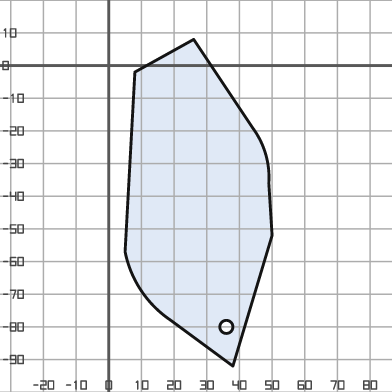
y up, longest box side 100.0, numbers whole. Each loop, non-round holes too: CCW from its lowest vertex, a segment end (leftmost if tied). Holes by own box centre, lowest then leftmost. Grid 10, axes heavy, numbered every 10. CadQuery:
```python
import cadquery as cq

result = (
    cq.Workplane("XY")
    .moveTo(38.0, -92.0)
    .lineTo(50.0, -52.0)
    .lineTo(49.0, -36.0)
    .threePointArc((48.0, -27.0), (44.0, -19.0))
    .lineTo(26.0, 8.0)
    .lineTo(8.0, -2.0)
    .lineTo(5.0, -57.0)
    .threePointArc((10.0, -69.0), (19.0, -78.0))
    .close()
    .moveTo(36.0, -80.0)
    .circle(2.0)
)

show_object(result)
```